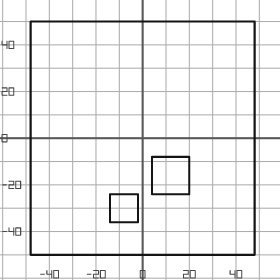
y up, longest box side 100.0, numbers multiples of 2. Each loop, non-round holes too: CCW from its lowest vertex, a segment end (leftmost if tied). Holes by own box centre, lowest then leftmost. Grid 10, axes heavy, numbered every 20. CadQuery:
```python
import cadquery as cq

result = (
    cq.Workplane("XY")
    .moveTo(-48.0, -50.0)
    .lineTo(48.0, -50.0)
    .lineTo(48.0, 50.0)
    .lineTo(-48.0, 50.0)
    .close()
    .moveTo(-14.0, -36.0)
    .lineTo(-2.0, -36.0)
    .lineTo(-2.0, -24.0)
    .lineTo(-14.0, -24.0)
    .close()
    .moveTo(4.0, -24.0)
    .lineTo(20.0, -24.0)
    .lineTo(20.0, -8.0)
    .lineTo(4.0, -8.0)
    .close()
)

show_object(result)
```